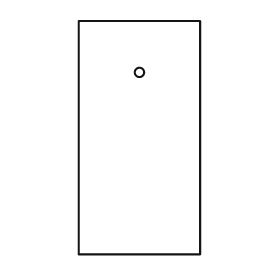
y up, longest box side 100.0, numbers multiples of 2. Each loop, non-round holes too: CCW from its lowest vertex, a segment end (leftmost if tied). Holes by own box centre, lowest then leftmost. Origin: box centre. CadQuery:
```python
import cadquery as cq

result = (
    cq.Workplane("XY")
    .moveTo(-26.0, -50.0)
    .lineTo(26.0, -50.0)
    .lineTo(26.0, 50.0)
    .lineTo(-26.0, 50.0)
    .close()
    .moveTo(0.0, 28.0)
    .circle(2.0)
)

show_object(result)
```